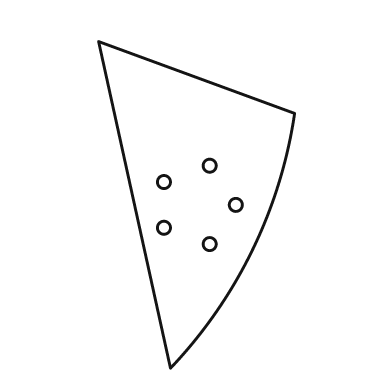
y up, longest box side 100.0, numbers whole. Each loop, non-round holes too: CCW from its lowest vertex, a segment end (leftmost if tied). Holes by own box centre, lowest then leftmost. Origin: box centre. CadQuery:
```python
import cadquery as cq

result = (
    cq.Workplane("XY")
    .moveTo(-8.0, -50.0)
    .threePointArc((17.0, -14.0), (30.0, 28.0))
    .lineTo(-30.0, 50.0)
    .close()
    .moveTo(4.0, -12.0)
    .circle(2.0)
    .moveTo(-10.0, -7.0)
    .circle(2.0)
    .moveTo(12.0, 0.0)
    .circle(2.0)
    .moveTo(-10.0, 7.0)
    .circle(2.0)
    .moveTo(4.0, 12.0)
    .circle(2.0)
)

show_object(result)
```